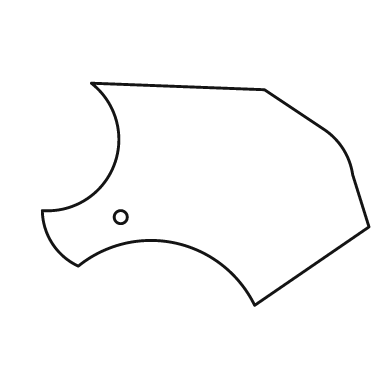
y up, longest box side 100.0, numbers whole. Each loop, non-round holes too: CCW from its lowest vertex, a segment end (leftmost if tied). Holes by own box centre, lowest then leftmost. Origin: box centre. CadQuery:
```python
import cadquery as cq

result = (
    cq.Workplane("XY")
    .moveTo(15.0, -34.0)
    .lineTo(50.0, -10.0)
    .lineTo(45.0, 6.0)
    .threePointArc((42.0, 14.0), (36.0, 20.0))
    .lineTo(18.0, 32.0)
    .lineTo(-35.0, 34.0)
    .threePointArc((-28.0, 9.0), (-50.0, -5.0))
    .threePointArc((-47.0, -15.0), (-39.0, -22.0))
    .threePointArc((-9.0, -15.0), (15.0, -34.0))
    .close()
    .moveTo(-26.0, -7.0)
    .circle(2.0)
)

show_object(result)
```